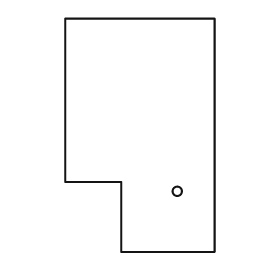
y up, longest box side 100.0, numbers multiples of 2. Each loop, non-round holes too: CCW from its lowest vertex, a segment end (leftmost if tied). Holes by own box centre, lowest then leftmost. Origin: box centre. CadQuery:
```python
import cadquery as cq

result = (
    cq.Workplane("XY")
    .moveTo(-8.0, -50.0)
    .lineTo(32.0, -50.0)
    .lineTo(32.0, 50.0)
    .lineTo(-32.0, 50.0)
    .lineTo(-32.0, -20.0)
    .lineTo(-8.0, -20.0)
    .close()
    .moveTo(16.0, -24.0)
    .circle(2.0)
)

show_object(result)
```